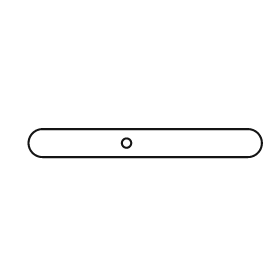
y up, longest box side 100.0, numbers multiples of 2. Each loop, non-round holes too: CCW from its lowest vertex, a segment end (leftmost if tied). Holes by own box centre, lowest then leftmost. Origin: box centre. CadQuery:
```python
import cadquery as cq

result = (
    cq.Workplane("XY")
    .moveTo(-44.0, -6.0)
    .lineTo(44.0, -6.0)
    .threePointArc((50.0, 0.0), (44.0, 6.0))
    .lineTo(-44.0, 6.0)
    .threePointArc((-50.0, 0.0), (-44.0, -6.0))
    .close()
    .moveTo(-8.0, 0.0)
    .circle(2.0)
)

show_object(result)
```